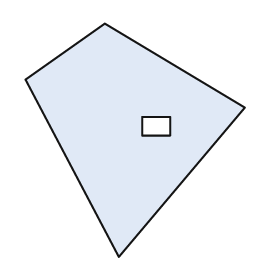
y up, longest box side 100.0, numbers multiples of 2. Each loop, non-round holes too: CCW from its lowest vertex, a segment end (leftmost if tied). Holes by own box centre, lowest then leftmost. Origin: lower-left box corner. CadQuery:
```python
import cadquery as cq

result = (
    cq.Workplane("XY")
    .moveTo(40.0, 0.0)
    .lineTo(94.0, 64.0)
    .lineTo(34.0, 100.0)
    .lineTo(0.0, 76.0)
    .close()
    .moveTo(50.0, 52.0)
    .lineTo(62.0, 52.0)
    .lineTo(62.0, 60.0)
    .lineTo(50.0, 60.0)
    .close()
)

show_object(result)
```